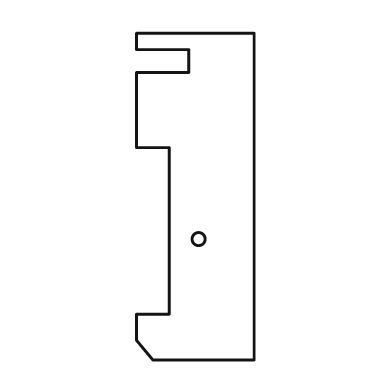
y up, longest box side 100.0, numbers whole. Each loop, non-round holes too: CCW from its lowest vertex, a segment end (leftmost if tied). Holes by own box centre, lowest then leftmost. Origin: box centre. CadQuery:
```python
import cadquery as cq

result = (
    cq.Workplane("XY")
    .moveTo(-13.0, -50.0)
    .lineTo(18.0, -50.0)
    .lineTo(18.0, 50.0)
    .lineTo(-18.0, 50.0)
    .lineTo(-18.0, 45.0)
    .lineTo(-2.0, 45.0)
    .lineTo(-2.0, 38.0)
    .lineTo(-18.0, 38.0)
    .lineTo(-18.0, 15.0)
    .lineTo(-8.0, 15.0)
    .lineTo(-8.0, -36.0)
    .lineTo(-18.0, -36.0)
    .lineTo(-18.0, -44.0)
    .close()
    .moveTo(1.0, -13.0)
    .circle(2.0)
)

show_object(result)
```